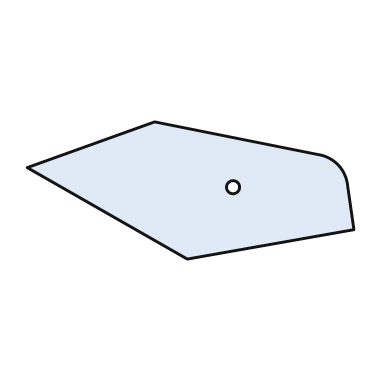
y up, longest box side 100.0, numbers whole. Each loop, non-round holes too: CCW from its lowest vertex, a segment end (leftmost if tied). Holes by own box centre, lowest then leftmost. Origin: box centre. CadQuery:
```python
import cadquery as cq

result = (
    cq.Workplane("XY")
    .moveTo(-1.0, -21.0)
    .lineTo(50.0, -12.0)
    .lineTo(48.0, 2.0)
    .threePointArc((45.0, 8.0), (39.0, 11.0))
    .lineTo(-11.0, 21.0)
    .lineTo(-50.0, 7.0)
    .close()
    .moveTo(13.0, 1.0)
    .circle(2.0)
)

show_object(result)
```